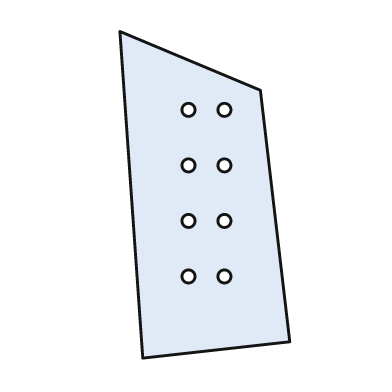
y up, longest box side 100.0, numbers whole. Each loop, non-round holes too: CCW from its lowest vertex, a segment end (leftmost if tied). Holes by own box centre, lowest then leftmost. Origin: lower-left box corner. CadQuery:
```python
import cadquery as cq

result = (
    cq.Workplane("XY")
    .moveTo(7.0, 0.0)
    .lineTo(52.0, 5.0)
    .lineTo(43.0, 82.0)
    .lineTo(0.0, 100.0)
    .close()
    .moveTo(21.0, 25.0)
    .circle(2.0)
    .moveTo(32.0, 25.0)
    .circle(2.0)
    .moveTo(21.0, 42.0)
    .circle(2.0)
    .moveTo(32.0, 42.0)
    .circle(2.0)
    .moveTo(21.0, 59.0)
    .circle(2.0)
    .moveTo(32.0, 59.0)
    .circle(2.0)
    .moveTo(21.0, 76.0)
    .circle(2.0)
    .moveTo(32.0, 76.0)
    .circle(2.0)
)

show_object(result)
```